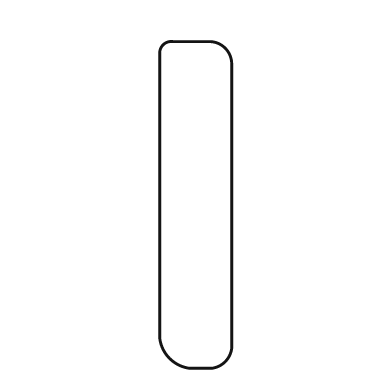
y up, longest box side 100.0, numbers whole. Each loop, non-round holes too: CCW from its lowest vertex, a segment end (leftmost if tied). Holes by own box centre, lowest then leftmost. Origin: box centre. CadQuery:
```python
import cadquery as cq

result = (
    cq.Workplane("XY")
    .moveTo(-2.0, -50.0)
    .lineTo(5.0, -50.0)
    .threePointArc((9.0, -48.0), (11.0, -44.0))
    .lineTo(11.0, 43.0)
    .threePointArc((9.0, 48.0), (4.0, 50.0))
    .lineTo(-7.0, 50.0)
    .threePointArc((-10.0, 49.0), (-11.0, 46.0))
    .lineTo(-11.0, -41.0)
    .threePointArc((-8.0, -47.0), (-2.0, -50.0))
    .close()
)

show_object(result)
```